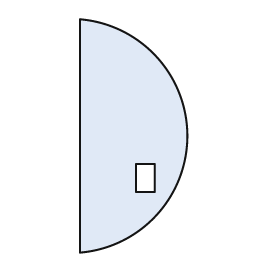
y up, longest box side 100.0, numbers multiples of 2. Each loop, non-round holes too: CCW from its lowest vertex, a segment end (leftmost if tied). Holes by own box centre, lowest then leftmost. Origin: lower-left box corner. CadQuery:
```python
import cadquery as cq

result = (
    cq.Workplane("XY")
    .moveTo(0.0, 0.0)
    .threePointArc((46.0, 50.0), (0.0, 100.0))
    .close()
    .moveTo(24.0, 26.0)
    .lineTo(32.0, 26.0)
    .lineTo(32.0, 38.0)
    .lineTo(24.0, 38.0)
    .close()
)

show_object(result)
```